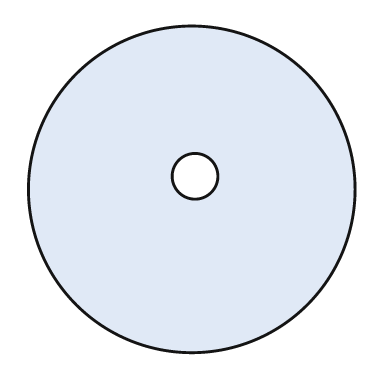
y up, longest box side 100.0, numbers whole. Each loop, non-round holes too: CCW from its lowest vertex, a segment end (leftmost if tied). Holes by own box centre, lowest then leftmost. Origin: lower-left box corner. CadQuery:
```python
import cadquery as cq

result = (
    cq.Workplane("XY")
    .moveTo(50.0, 50.0)
    .circle(50.0)
    .moveTo(51.0, 54.0)
    .circle(7.0)
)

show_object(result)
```